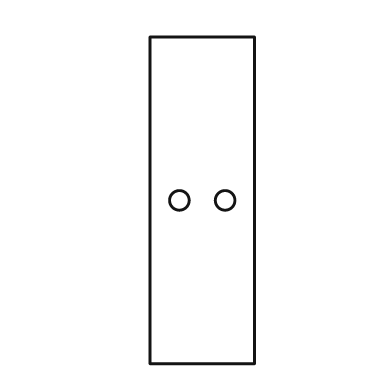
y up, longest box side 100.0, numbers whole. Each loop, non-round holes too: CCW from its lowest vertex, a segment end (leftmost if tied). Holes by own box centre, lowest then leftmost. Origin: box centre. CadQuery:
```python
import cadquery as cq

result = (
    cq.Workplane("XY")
    .moveTo(-16.0, -50.0)
    .lineTo(16.0, -50.0)
    .lineTo(16.0, 50.0)
    .lineTo(-16.0, 50.0)
    .close()
    .moveTo(-7.0, 0.0)
    .circle(3.0)
    .moveTo(7.0, 0.0)
    .circle(3.0)
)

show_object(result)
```